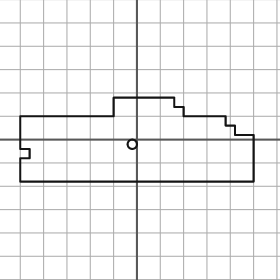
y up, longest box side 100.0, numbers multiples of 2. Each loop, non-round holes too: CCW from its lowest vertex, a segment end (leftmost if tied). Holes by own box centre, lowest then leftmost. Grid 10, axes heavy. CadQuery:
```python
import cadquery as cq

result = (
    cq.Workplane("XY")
    .moveTo(-50.0, -18.0)
    .lineTo(50.0, -18.0)
    .lineTo(50.0, 2.0)
    .lineTo(42.0, 2.0)
    .lineTo(42.0, 6.0)
    .lineTo(38.0, 6.0)
    .lineTo(38.0, 10.0)
    .lineTo(20.0, 10.0)
    .lineTo(20.0, 14.0)
    .lineTo(16.0, 14.0)
    .lineTo(16.0, 18.0)
    .lineTo(-10.0, 18.0)
    .lineTo(-10.0, 10.0)
    .lineTo(-50.0, 10.0)
    .lineTo(-50.0, -4.0)
    .lineTo(-46.0, -4.0)
    .lineTo(-46.0, -8.0)
    .lineTo(-50.0, -8.0)
    .close()
    .moveTo(-2.0, -2.0)
    .circle(2.0)
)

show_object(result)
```